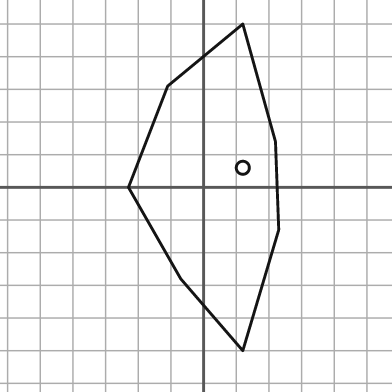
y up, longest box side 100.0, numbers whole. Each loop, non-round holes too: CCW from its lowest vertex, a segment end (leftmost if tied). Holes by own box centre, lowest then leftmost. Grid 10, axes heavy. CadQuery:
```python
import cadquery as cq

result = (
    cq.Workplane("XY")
    .moveTo(12.0, -50.0)
    .lineTo(23.0, -13.0)
    .lineTo(22.0, 14.0)
    .lineTo(12.0, 50.0)
    .lineTo(-11.0, 31.0)
    .lineTo(-23.0, 0.0)
    .lineTo(-7.0, -28.0)
    .close()
    .moveTo(12.0, 6.0)
    .circle(2.0)
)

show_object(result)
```